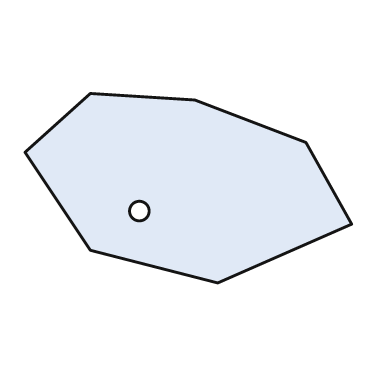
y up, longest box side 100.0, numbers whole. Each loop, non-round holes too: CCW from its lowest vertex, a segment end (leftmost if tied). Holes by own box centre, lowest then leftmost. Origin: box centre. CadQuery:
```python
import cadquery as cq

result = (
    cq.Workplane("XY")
    .moveTo(9.0, -29.0)
    .lineTo(50.0, -11.0)
    .lineTo(36.0, 14.0)
    .lineTo(2.0, 27.0)
    .lineTo(-30.0, 29.0)
    .lineTo(-50.0, 11.0)
    .lineTo(-30.0, -19.0)
    .close()
    .moveTo(-15.0, -7.0)
    .circle(3.0)
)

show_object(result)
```